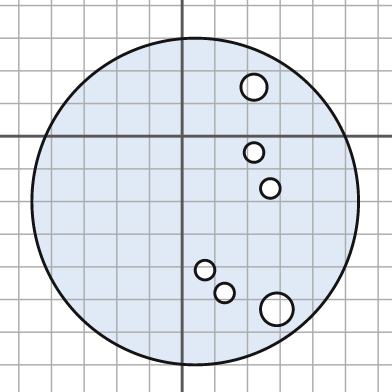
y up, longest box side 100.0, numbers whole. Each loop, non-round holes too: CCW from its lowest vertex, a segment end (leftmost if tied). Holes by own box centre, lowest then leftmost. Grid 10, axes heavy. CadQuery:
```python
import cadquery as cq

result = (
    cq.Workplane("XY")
    .moveTo(4.0, -20.0)
    .circle(50.0)
    .moveTo(29.0, -53.0)
    .circle(5.0)
    .moveTo(13.0, -48.0)
    .circle(3.0)
    .moveTo(7.0, -41.0)
    .circle(3.0)
    .moveTo(27.0, -16.0)
    .circle(3.0)
    .moveTo(22.0, -5.0)
    .circle(3.0)
    .moveTo(22.0, 15.0)
    .circle(4.0)
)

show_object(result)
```